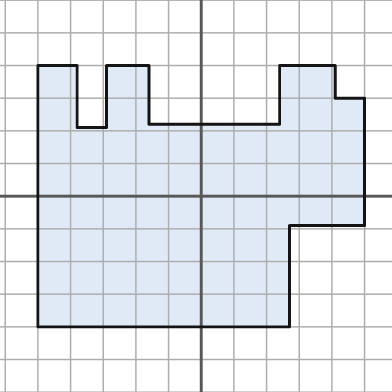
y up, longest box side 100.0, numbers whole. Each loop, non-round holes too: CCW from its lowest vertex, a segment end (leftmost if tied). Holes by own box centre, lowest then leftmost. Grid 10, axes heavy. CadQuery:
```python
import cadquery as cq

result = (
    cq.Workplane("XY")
    .moveTo(-50.0, -40.0)
    .lineTo(27.0, -40.0)
    .lineTo(27.0, -9.0)
    .lineTo(50.0, -9.0)
    .lineTo(50.0, 30.0)
    .lineTo(41.0, 30.0)
    .lineTo(41.0, 40.0)
    .lineTo(24.0, 40.0)
    .lineTo(24.0, 22.0)
    .lineTo(-16.0, 22.0)
    .lineTo(-16.0, 40.0)
    .lineTo(-29.0, 40.0)
    .lineTo(-29.0, 21.0)
    .lineTo(-38.0, 21.0)
    .lineTo(-38.0, 40.0)
    .lineTo(-50.0, 40.0)
    .close()
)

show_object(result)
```